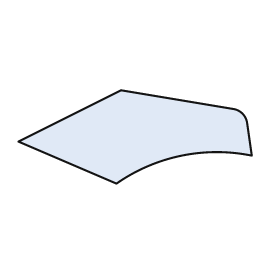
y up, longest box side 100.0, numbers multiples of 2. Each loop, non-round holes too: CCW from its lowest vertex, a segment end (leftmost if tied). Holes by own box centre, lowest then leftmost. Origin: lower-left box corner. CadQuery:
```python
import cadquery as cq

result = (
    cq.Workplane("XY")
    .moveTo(42.0, 0.0)
    .threePointArc((70.0, 12.0), (100.0, 12.0))
    .lineTo(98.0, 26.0)
    .threePointArc((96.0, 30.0), (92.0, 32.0))
    .lineTo(44.0, 40.0)
    .lineTo(0.0, 18.0)
    .close()
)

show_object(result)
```